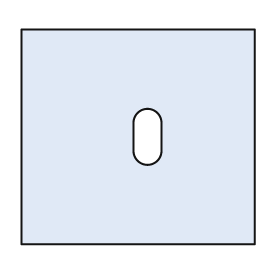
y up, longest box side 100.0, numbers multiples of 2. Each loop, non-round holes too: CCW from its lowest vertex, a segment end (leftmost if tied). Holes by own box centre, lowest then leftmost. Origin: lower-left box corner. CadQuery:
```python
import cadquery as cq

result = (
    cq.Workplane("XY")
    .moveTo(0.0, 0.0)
    .lineTo(100.0, 0.0)
    .lineTo(100.0, 92.0)
    .lineTo(0.0, 92.0)
    .close()
    .moveTo(48.0, 40.0)
    .threePointArc((54.0, 34.0), (60.0, 40.0))
    .lineTo(60.0, 52.0)
    .threePointArc((54.0, 58.0), (48.0, 52.0))
    .close()
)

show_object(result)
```